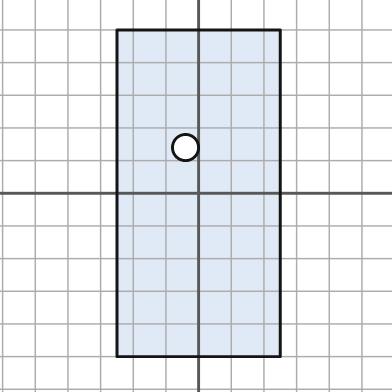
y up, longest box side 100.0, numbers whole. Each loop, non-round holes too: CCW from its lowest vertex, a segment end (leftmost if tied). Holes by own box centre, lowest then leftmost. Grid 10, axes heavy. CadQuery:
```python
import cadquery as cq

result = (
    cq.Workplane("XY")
    .moveTo(-25.0, -50.0)
    .lineTo(25.0, -50.0)
    .lineTo(25.0, 50.0)
    .lineTo(-25.0, 50.0)
    .close()
    .moveTo(-4.0, 14.0)
    .circle(4.0)
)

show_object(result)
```